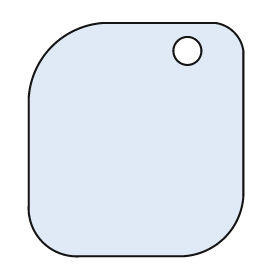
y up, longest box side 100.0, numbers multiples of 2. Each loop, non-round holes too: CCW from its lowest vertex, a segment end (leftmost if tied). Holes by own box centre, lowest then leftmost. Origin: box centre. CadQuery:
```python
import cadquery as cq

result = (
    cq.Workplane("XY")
    .moveTo(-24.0, -50.0)
    .lineTo(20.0, -50.0)
    .threePointArc((38.0, -42.0), (46.0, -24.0))
    .lineTo(46.0, 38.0)
    .threePointArc((42.0, 46.0), (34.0, 50.0))
    .lineTo(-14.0, 50.0)
    .threePointArc((-36.0, 40.0), (-46.0, 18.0))
    .lineTo(-46.0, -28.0)
    .threePointArc((-40.0, -44.0), (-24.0, -50.0))
    .close()
    .moveTo(22.0, 38.0)
    .circle(6.0)
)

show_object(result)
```